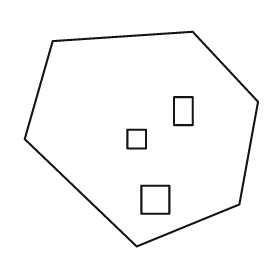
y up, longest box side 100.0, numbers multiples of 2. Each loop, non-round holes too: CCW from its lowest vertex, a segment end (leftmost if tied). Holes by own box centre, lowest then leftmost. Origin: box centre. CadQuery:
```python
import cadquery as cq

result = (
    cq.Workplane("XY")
    .moveTo(-2.0, -46.0)
    .lineTo(42.0, -28.0)
    .lineTo(50.0, 16.0)
    .lineTo(22.0, 46.0)
    .lineTo(-38.0, 42.0)
    .lineTo(-50.0, 0.0)
    .close()
    .moveTo(0.0, -32.0)
    .lineTo(12.0, -32.0)
    .lineTo(12.0, -20.0)
    .lineTo(0.0, -20.0)
    .close()
    .moveTo(-6.0, -4.0)
    .lineTo(2.0, -4.0)
    .lineTo(2.0, 4.0)
    .lineTo(-6.0, 4.0)
    .close()
    .moveTo(14.0, 6.0)
    .lineTo(22.0, 6.0)
    .lineTo(22.0, 18.0)
    .lineTo(14.0, 18.0)
    .close()
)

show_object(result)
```